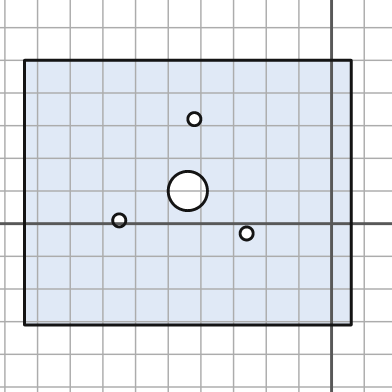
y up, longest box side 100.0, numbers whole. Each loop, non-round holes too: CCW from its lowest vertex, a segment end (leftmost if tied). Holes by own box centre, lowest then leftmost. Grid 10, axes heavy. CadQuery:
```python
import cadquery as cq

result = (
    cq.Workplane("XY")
    .moveTo(-94.0, -31.0)
    .lineTo(6.0, -31.0)
    .lineTo(6.0, 50.0)
    .lineTo(-94.0, 50.0)
    .close()
    .moveTo(-26.0, -3.0)
    .circle(2.0)
    .moveTo(-65.0, 1.0)
    .circle(2.0)
    .moveTo(-44.0, 10.0)
    .circle(6.0)
    .moveTo(-42.0, 32.0)
    .circle(2.0)
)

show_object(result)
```